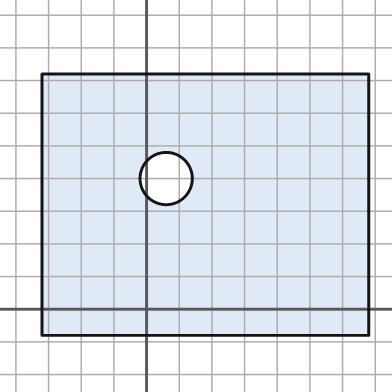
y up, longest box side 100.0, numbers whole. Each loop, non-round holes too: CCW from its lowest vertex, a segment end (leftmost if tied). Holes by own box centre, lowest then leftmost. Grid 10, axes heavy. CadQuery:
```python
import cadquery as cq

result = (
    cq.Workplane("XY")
    .moveTo(-32.0, -8.0)
    .lineTo(68.0, -8.0)
    .lineTo(68.0, 72.0)
    .lineTo(-32.0, 72.0)
    .close()
    .moveTo(6.0, 40.0)
    .circle(8.0)
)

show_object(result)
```